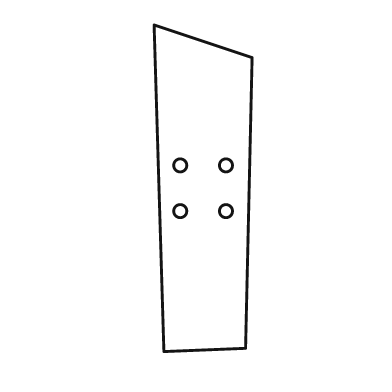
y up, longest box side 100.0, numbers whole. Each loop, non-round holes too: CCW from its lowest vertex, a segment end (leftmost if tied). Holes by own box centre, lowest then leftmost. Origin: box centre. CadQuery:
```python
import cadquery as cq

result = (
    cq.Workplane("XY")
    .moveTo(-12.0, -50.0)
    .lineTo(13.0, -49.0)
    .lineTo(15.0, 40.0)
    .lineTo(-15.0, 50.0)
    .close()
    .moveTo(-7.0, -7.0)
    .circle(2.0)
    .moveTo(7.0, -7.0)
    .circle(2.0)
    .moveTo(-7.0, 7.0)
    .circle(2.0)
    .moveTo(7.0, 7.0)
    .circle(2.0)
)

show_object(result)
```